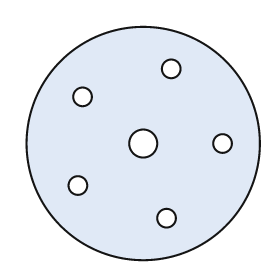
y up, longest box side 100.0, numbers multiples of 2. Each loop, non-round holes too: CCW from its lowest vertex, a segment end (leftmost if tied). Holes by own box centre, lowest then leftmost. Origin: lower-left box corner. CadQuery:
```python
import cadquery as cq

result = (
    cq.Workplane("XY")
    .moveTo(50.0, 50.0)
    .circle(50.0)
    .moveTo(60.0, 18.0)
    .circle(4.0)
    .moveTo(22.0, 32.0)
    .circle(4.0)
    .moveTo(50.0, 50.0)
    .circle(6.0)
    .moveTo(84.0, 50.0)
    .circle(4.0)
    .moveTo(24.0, 70.0)
    .circle(4.0)
    .moveTo(62.0, 82.0)
    .circle(4.0)
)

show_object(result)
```